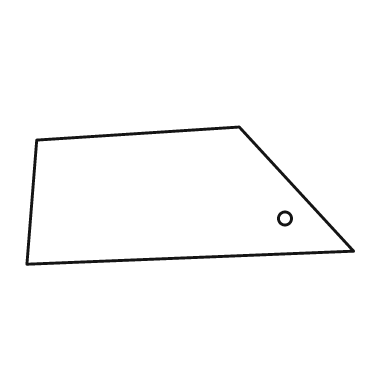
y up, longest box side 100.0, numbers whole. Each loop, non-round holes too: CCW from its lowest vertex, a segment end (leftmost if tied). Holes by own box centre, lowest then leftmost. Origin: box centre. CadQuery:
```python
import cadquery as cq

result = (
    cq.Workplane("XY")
    .moveTo(-50.0, -21.0)
    .lineTo(50.0, -17.0)
    .lineTo(15.0, 21.0)
    .lineTo(-47.0, 17.0)
    .close()
    .moveTo(29.0, -7.0)
    .circle(2.0)
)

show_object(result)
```